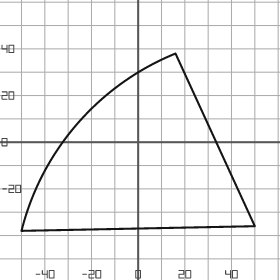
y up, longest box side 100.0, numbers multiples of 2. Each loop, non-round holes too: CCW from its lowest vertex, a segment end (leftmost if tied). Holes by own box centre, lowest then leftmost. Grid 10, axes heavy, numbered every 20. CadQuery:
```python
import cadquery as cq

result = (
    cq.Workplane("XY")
    .moveTo(-50.0, -38.0)
    .lineTo(50.0, -36.0)
    .lineTo(16.0, 38.0)
    .threePointArc((-26.0, 8.0), (-50.0, -38.0))
    .close()
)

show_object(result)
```